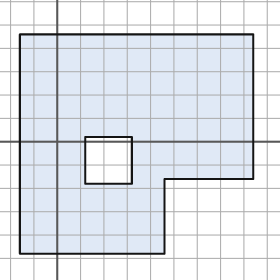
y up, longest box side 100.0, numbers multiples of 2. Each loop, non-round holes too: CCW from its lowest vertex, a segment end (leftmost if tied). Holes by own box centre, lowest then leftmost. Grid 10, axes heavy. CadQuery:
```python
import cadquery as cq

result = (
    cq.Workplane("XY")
    .moveTo(-16.0, -48.0)
    .lineTo(46.0, -48.0)
    .lineTo(46.0, -16.0)
    .lineTo(84.0, -16.0)
    .lineTo(84.0, 46.0)
    .lineTo(-16.0, 46.0)
    .close()
    .moveTo(12.0, -18.0)
    .lineTo(32.0, -18.0)
    .lineTo(32.0, 2.0)
    .lineTo(12.0, 2.0)
    .close()
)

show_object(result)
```